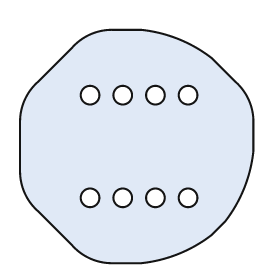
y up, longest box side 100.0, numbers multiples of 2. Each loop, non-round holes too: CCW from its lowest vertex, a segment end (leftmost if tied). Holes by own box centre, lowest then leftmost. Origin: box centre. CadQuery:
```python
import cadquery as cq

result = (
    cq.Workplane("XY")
    .moveTo(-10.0, -50.0)
    .lineTo(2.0, -50.0)
    .threePointArc((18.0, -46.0), (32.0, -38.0))
    .lineTo(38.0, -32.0)
    .threePointArc((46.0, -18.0), (50.0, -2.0))
    .lineTo(50.0, 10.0)
    .threePointArc((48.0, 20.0), (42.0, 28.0))
    .lineTo(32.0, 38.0)
    .threePointArc((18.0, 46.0), (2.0, 50.0))
    .lineTo(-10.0, 50.0)
    .threePointArc((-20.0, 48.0), (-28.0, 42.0))
    .lineTo(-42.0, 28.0)
    .threePointArc((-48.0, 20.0), (-50.0, 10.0))
    .lineTo(-50.0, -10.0)
    .threePointArc((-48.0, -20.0), (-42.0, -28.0))
    .lineTo(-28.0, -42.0)
    .threePointArc((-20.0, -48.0), (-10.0, -50.0))
    .close()
    .moveTo(-20.0, -22.0)
    .circle(4.0)
    .moveTo(-6.0, -22.0)
    .circle(4.0)
    .moveTo(8.0, -22.0)
    .circle(4.0)
    .moveTo(22.0, -22.0)
    .circle(4.0)
    .moveTo(-20.0, 22.0)
    .circle(4.0)
    .moveTo(-6.0, 22.0)
    .circle(4.0)
    .moveTo(8.0, 22.0)
    .circle(4.0)
    .moveTo(22.0, 22.0)
    .circle(4.0)
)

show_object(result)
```